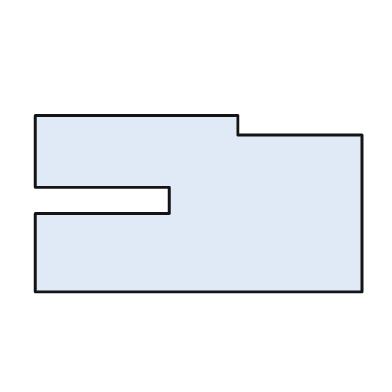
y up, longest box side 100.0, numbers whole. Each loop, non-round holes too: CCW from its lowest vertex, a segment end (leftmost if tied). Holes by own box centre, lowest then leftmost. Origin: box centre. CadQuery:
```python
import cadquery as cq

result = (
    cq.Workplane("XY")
    .moveTo(-50.0, -27.0)
    .lineTo(50.0, -27.0)
    .lineTo(50.0, 21.0)
    .lineTo(12.0, 21.0)
    .lineTo(12.0, 27.0)
    .lineTo(-50.0, 27.0)
    .lineTo(-50.0, 5.0)
    .lineTo(-9.0, 5.0)
    .lineTo(-9.0, -3.0)
    .lineTo(-50.0, -3.0)
    .close()
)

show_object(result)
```